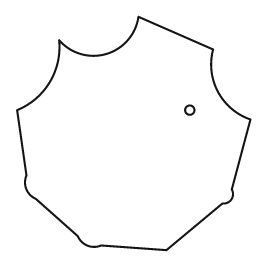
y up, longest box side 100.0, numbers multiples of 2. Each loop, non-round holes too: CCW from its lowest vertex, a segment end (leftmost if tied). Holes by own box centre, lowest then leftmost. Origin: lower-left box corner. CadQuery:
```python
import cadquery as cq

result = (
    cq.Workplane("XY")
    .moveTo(64.0, 0.0)
    .lineTo(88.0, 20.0)
    .threePointArc((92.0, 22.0), (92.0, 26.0))
    .lineTo(100.0, 56.0)
    .threePointArc((86.0, 68.0), (84.0, 86.0))
    .lineTo(52.0, 100.0)
    .threePointArc((38.0, 84.0), (18.0, 90.0))
    .threePointArc((14.0, 72.0), (0.0, 60.0))
    .lineTo(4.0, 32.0)
    .threePointArc((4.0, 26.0), (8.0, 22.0))
    .lineTo(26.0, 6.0)
    .threePointArc((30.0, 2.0), (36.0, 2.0))
    .close()
    .moveTo(74.0, 60.0)
    .circle(2.0)
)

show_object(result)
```